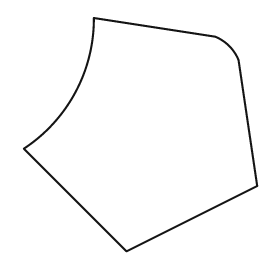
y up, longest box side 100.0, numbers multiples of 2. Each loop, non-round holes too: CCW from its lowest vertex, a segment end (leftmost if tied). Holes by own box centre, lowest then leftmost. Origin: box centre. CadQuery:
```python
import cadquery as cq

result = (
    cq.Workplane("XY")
    .moveTo(-6.0, -50.0)
    .lineTo(50.0, -22.0)
    .lineTo(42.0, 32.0)
    .threePointArc((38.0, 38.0), (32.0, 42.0))
    .lineTo(-20.0, 50.0)
    .threePointArc((-28.0, 18.0), (-50.0, -6.0))
    .close()
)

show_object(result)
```